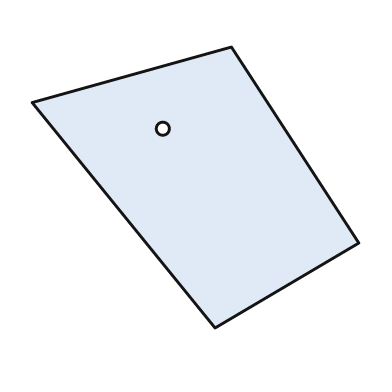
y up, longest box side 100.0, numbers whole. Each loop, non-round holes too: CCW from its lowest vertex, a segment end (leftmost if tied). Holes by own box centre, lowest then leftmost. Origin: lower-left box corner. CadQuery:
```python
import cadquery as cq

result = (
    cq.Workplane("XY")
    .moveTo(56.0, 0.0)
    .lineTo(100.0, 26.0)
    .lineTo(61.0, 86.0)
    .lineTo(0.0, 69.0)
    .close()
    .moveTo(40.0, 61.0)
    .circle(2.0)
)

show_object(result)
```